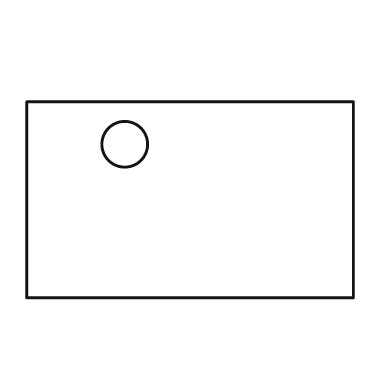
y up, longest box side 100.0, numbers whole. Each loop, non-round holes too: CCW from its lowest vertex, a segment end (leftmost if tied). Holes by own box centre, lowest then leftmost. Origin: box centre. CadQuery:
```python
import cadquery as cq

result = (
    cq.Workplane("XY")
    .moveTo(-50.0, -30.0)
    .lineTo(50.0, -30.0)
    .lineTo(50.0, 30.0)
    .lineTo(-50.0, 30.0)
    .close()
    .moveTo(-20.0, 17.0)
    .circle(7.0)
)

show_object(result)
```